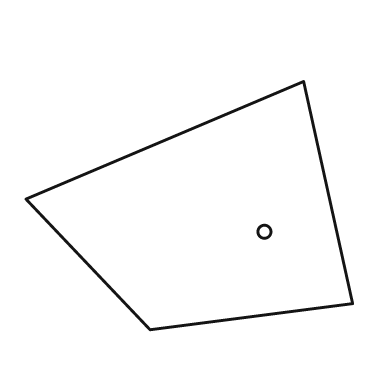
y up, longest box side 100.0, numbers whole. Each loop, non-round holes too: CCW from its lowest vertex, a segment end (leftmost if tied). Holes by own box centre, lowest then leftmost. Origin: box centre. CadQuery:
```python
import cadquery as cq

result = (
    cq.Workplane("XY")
    .moveTo(-12.0, -38.0)
    .lineTo(50.0, -30.0)
    .lineTo(35.0, 38.0)
    .lineTo(-50.0, 2.0)
    .close()
    .moveTo(23.0, -8.0)
    .circle(2.0)
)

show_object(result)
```